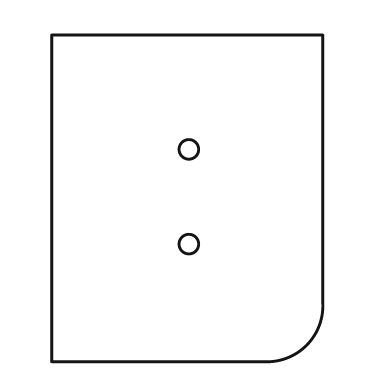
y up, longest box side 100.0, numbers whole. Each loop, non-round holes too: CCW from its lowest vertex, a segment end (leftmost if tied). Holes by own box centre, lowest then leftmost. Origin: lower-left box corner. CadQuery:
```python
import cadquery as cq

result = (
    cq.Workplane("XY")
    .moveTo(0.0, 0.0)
    .lineTo(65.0, 0.0)
    .threePointArc((78.0, 5.0), (83.0, 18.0))
    .lineTo(83.0, 100.0)
    .lineTo(0.0, 100.0)
    .close()
    .moveTo(42.0, 36.0)
    .circle(3.0)
    .moveTo(42.0, 65.0)
    .circle(3.0)
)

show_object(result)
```